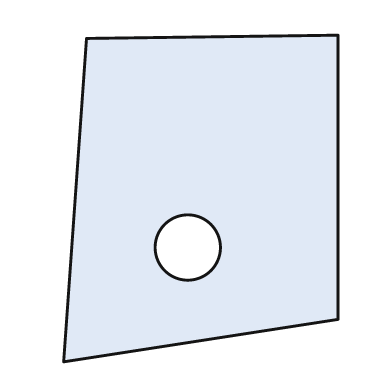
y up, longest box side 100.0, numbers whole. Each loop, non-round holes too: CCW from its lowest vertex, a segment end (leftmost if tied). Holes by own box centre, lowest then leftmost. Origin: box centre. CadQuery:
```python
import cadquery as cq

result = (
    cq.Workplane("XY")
    .moveTo(-42.0, -50.0)
    .lineTo(42.0, -37.0)
    .lineTo(42.0, 50.0)
    .lineTo(-35.0, 49.0)
    .close()
    .moveTo(-4.0, -15.0)
    .circle(10.0)
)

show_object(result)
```